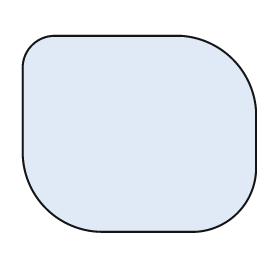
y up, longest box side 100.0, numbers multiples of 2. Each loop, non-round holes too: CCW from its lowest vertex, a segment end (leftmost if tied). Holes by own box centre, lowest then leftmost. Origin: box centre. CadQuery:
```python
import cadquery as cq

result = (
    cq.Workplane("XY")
    .moveTo(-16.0, -42.0)
    .lineTo(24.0, -42.0)
    .threePointArc((42.0, -34.0), (50.0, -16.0))
    .lineTo(50.0, 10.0)
    .threePointArc((40.0, 32.0), (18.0, 42.0))
    .lineTo(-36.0, 42.0)
    .threePointArc((-46.0, 38.0), (-50.0, 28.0))
    .lineTo(-50.0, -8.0)
    .threePointArc((-40.0, -32.0), (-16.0, -42.0))
    .close()
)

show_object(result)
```